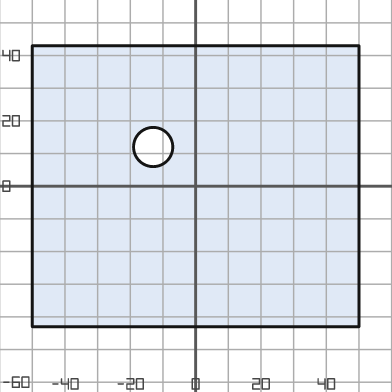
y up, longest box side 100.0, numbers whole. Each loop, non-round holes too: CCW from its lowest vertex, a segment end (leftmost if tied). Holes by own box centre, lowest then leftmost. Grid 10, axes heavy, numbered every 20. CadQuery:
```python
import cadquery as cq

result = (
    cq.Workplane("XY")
    .moveTo(-50.0, -43.0)
    .lineTo(50.0, -43.0)
    .lineTo(50.0, 43.0)
    .lineTo(-50.0, 43.0)
    .close()
    .moveTo(-13.0, 12.0)
    .circle(6.0)
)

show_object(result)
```